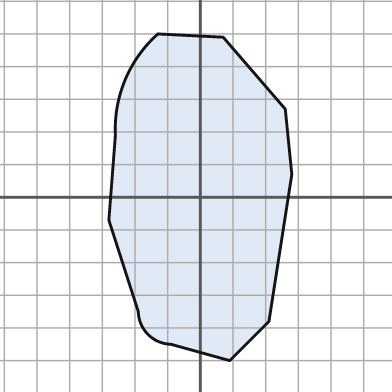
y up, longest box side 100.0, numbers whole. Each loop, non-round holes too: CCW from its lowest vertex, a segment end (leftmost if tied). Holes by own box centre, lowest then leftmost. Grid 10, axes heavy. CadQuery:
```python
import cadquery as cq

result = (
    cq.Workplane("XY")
    .moveTo(9.0, -50.0)
    .lineTo(21.0, -38.0)
    .lineTo(28.0, 7.0)
    .lineTo(26.0, 27.0)
    .lineTo(7.0, 49.0)
    .lineTo(-13.0, 50.0)
    .threePointArc((-23.0, 36.0), (-26.0, 19.0))
    .lineTo(-28.0, -7.0)
    .lineTo(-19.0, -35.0)
    .threePointArc((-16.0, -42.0), (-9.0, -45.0))
    .close()
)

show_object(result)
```